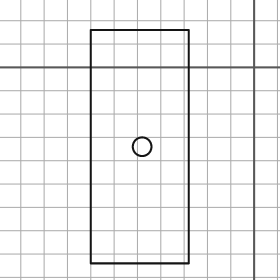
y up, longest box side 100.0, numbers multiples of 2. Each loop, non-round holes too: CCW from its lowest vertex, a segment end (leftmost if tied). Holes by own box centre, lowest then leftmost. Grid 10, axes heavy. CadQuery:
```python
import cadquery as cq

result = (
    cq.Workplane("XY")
    .moveTo(-70.0, -84.0)
    .lineTo(-28.0, -84.0)
    .lineTo(-28.0, 16.0)
    .lineTo(-70.0, 16.0)
    .close()
    .moveTo(-48.0, -34.0)
    .circle(4.0)
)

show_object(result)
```